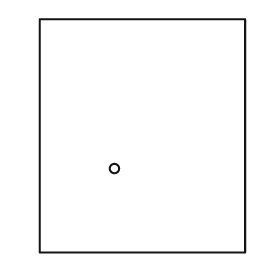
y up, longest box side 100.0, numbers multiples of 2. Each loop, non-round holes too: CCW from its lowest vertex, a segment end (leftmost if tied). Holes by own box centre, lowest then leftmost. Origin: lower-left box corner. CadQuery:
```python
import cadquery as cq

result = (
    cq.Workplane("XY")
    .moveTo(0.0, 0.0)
    .lineTo(88.0, 0.0)
    .lineTo(88.0, 100.0)
    .lineTo(0.0, 100.0)
    .close()
    .moveTo(32.0, 36.0)
    .circle(2.0)
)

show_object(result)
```